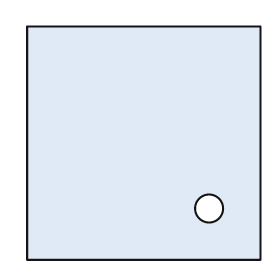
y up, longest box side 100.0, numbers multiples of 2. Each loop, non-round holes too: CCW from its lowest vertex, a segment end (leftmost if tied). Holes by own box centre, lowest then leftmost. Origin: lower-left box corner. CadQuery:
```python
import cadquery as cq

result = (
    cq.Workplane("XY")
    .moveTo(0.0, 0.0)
    .lineTo(100.0, 0.0)
    .lineTo(100.0, 100.0)
    .lineTo(0.0, 100.0)
    .close()
    .moveTo(78.0, 22.0)
    .circle(6.0)
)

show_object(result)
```